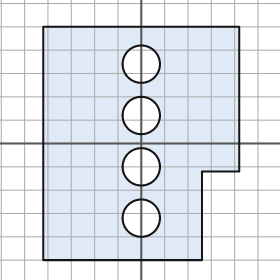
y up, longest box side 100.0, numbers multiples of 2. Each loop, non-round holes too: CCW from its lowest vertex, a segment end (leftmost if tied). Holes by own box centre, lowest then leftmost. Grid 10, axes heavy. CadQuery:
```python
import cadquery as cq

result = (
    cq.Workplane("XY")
    .moveTo(-42.0, -50.0)
    .lineTo(26.0, -50.0)
    .lineTo(26.0, -12.0)
    .lineTo(42.0, -12.0)
    .lineTo(42.0, 50.0)
    .lineTo(-42.0, 50.0)
    .close()
    .moveTo(0.0, -32.0)
    .circle(8.0)
    .moveTo(0.0, -10.0)
    .circle(8.0)
    .moveTo(0.0, 12.0)
    .circle(8.0)
    .moveTo(0.0, 34.0)
    .circle(8.0)
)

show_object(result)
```